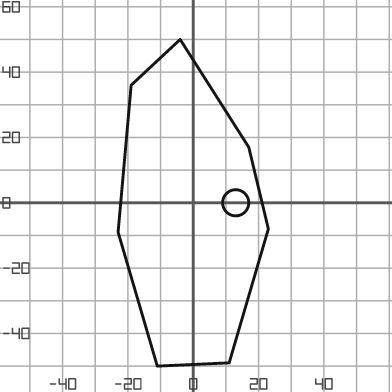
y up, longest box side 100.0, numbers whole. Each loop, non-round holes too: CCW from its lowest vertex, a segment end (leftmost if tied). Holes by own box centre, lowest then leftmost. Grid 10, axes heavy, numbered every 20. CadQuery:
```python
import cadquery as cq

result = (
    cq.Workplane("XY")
    .moveTo(-11.0, -50.0)
    .lineTo(11.0, -49.0)
    .lineTo(23.0, -8.0)
    .lineTo(17.0, 17.0)
    .lineTo(-4.0, 50.0)
    .lineTo(-19.0, 36.0)
    .lineTo(-23.0, -9.0)
    .close()
    .moveTo(13.0, 0.0)
    .circle(4.0)
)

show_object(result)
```